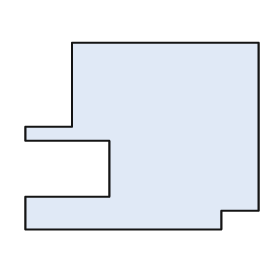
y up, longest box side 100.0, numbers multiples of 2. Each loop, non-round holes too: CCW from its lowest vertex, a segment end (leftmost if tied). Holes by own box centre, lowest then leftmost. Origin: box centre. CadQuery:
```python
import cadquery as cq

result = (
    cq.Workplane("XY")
    .moveTo(-50.0, -40.0)
    .lineTo(34.0, -40.0)
    .lineTo(34.0, -32.0)
    .lineTo(50.0, -32.0)
    .lineTo(50.0, 40.0)
    .lineTo(-30.0, 40.0)
    .lineTo(-30.0, 4.0)
    .lineTo(-50.0, 4.0)
    .lineTo(-50.0, -2.0)
    .lineTo(-14.0, -2.0)
    .lineTo(-14.0, -26.0)
    .lineTo(-50.0, -26.0)
    .close()
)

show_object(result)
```